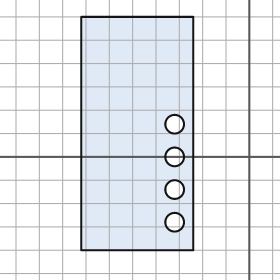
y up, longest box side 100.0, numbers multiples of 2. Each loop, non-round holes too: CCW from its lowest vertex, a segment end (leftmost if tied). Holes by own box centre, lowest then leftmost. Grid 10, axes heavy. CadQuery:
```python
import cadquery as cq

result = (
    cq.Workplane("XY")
    .moveTo(-72.0, -40.0)
    .lineTo(-24.0, -40.0)
    .lineTo(-24.0, 60.0)
    .lineTo(-72.0, 60.0)
    .close()
    .moveTo(-32.0, -28.0)
    .circle(4.0)
    .moveTo(-32.0, -14.0)
    .circle(4.0)
    .moveTo(-32.0, 0.0)
    .circle(4.0)
    .moveTo(-32.0, 14.0)
    .circle(4.0)
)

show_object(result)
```